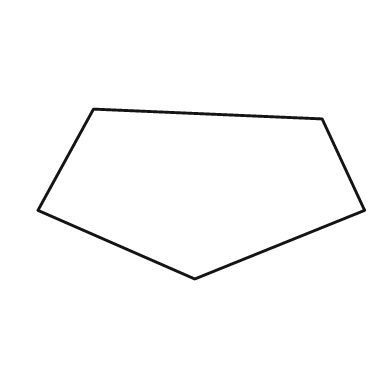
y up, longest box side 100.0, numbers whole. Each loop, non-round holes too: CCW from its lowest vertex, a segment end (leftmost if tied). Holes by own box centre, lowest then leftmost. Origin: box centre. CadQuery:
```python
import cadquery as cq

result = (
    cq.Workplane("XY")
    .moveTo(-2.0, -26.0)
    .lineTo(50.0, -5.0)
    .lineTo(37.0, 23.0)
    .lineTo(-33.0, 26.0)
    .lineTo(-50.0, -5.0)
    .close()
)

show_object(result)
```